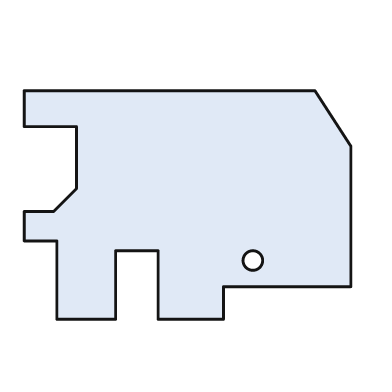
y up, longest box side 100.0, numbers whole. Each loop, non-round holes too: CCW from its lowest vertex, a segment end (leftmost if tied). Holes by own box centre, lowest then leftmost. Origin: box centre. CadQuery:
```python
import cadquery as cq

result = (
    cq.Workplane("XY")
    .moveTo(-40.0, -35.0)
    .lineTo(-22.0, -35.0)
    .lineTo(-22.0, -14.0)
    .lineTo(-9.0, -14.0)
    .lineTo(-9.0, -35.0)
    .lineTo(11.0, -35.0)
    .lineTo(11.0, -25.0)
    .lineTo(50.0, -25.0)
    .lineTo(50.0, 18.0)
    .lineTo(39.0, 35.0)
    .lineTo(-50.0, 35.0)
    .lineTo(-50.0, 24.0)
    .lineTo(-34.0, 24.0)
    .lineTo(-34.0, 5.0)
    .lineTo(-41.0, -2.0)
    .lineTo(-50.0, -2.0)
    .lineTo(-50.0, -11.0)
    .lineTo(-40.0, -11.0)
    .close()
    .moveTo(20.0, -17.0)
    .circle(3.0)
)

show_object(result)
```